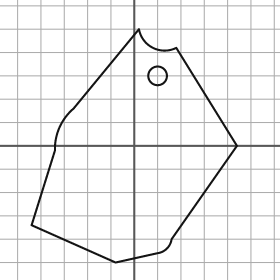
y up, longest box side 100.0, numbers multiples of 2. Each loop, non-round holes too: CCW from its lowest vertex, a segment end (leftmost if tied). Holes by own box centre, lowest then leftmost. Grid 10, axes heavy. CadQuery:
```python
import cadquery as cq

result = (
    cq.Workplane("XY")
    .moveTo(-8.0, -50.0)
    .lineTo(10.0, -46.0)
    .threePointArc((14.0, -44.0), (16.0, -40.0))
    .lineTo(44.0, 0.0)
    .lineTo(18.0, 42.0)
    .threePointArc((8.0, 42.0), (2.0, 50.0))
    .lineTo(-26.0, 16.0)
    .threePointArc((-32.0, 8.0), (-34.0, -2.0))
    .lineTo(-44.0, -34.0)
    .close()
    .moveTo(10.0, 30.0)
    .circle(4.0)
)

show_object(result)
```